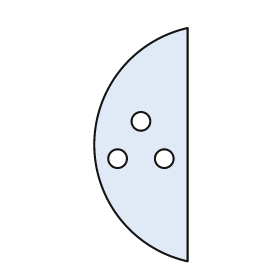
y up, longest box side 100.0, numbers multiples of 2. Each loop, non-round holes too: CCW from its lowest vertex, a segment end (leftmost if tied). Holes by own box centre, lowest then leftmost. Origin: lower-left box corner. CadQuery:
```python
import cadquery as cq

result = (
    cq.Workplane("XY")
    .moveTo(40.0, 0.0)
    .lineTo(40.0, 100.0)
    .threePointArc((0.0, 50.0), (40.0, 0.0))
    .close()
    .moveTo(10.0, 44.0)
    .circle(4.0)
    .moveTo(30.0, 44.0)
    .circle(4.0)
    .moveTo(20.0, 60.0)
    .circle(4.0)
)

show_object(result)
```